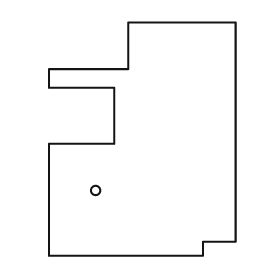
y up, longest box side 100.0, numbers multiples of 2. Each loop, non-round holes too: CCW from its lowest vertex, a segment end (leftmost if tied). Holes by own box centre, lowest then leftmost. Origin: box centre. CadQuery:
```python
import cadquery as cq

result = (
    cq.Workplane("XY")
    .moveTo(-40.0, -50.0)
    .lineTo(26.0, -50.0)
    .lineTo(26.0, -44.0)
    .lineTo(40.0, -44.0)
    .lineTo(40.0, 50.0)
    .lineTo(-6.0, 50.0)
    .lineTo(-6.0, 30.0)
    .lineTo(-40.0, 30.0)
    .lineTo(-40.0, 22.0)
    .lineTo(-12.0, 22.0)
    .lineTo(-12.0, -2.0)
    .lineTo(-40.0, -2.0)
    .close()
    .moveTo(-20.0, -22.0)
    .circle(2.0)
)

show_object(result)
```